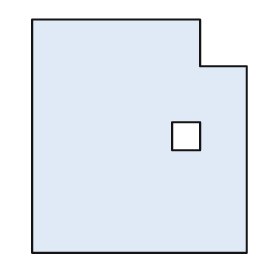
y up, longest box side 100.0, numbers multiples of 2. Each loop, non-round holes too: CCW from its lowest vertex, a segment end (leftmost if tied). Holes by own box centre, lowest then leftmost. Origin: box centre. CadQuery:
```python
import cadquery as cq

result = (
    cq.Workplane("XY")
    .moveTo(-46.0, -50.0)
    .lineTo(46.0, -50.0)
    .lineTo(46.0, 30.0)
    .lineTo(26.0, 30.0)
    .lineTo(26.0, 50.0)
    .lineTo(-46.0, 50.0)
    .close()
    .moveTo(14.0, -6.0)
    .lineTo(26.0, -6.0)
    .lineTo(26.0, 6.0)
    .lineTo(14.0, 6.0)
    .close()
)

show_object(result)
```